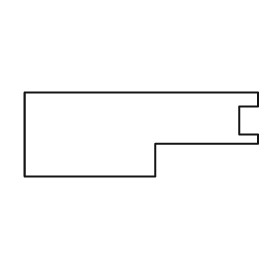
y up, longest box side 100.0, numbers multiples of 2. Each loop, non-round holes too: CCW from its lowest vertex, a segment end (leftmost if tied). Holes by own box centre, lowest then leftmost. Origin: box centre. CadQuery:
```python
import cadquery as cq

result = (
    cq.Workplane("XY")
    .moveTo(-50.0, -18.0)
    .lineTo(6.0, -18.0)
    .lineTo(6.0, -4.0)
    .lineTo(50.0, -4.0)
    .lineTo(50.0, 0.0)
    .lineTo(42.0, 0.0)
    .lineTo(42.0, 12.0)
    .lineTo(50.0, 12.0)
    .lineTo(50.0, 18.0)
    .lineTo(-50.0, 18.0)
    .close()
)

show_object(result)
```